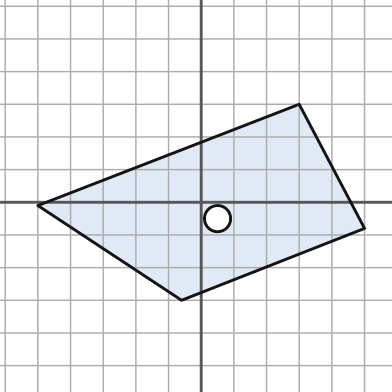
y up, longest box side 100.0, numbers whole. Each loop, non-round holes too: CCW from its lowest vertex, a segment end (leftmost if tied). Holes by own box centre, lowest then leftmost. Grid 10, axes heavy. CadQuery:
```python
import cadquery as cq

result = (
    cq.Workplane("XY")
    .moveTo(-6.0, -30.0)
    .lineTo(50.0, -8.0)
    .lineTo(30.0, 30.0)
    .lineTo(-50.0, -1.0)
    .close()
    .moveTo(5.0, -5.0)
    .circle(4.0)
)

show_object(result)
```